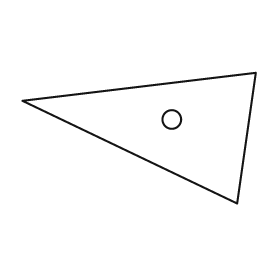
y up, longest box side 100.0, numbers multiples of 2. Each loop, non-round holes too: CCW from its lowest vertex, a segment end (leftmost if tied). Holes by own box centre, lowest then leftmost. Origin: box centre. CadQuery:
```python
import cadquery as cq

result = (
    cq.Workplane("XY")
    .moveTo(42.0, -28.0)
    .lineTo(50.0, 28.0)
    .lineTo(-50.0, 16.0)
    .close()
    .moveTo(14.0, 8.0)
    .circle(4.0)
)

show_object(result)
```